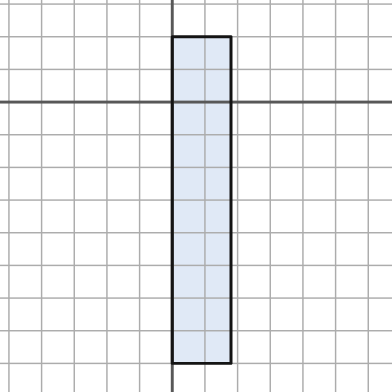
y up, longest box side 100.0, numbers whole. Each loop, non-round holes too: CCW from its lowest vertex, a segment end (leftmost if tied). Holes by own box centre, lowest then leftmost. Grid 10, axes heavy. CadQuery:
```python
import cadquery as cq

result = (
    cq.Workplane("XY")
    .moveTo(0.0, -80.0)
    .lineTo(18.0, -80.0)
    .lineTo(18.0, 20.0)
    .lineTo(0.0, 20.0)
    .close()
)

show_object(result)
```